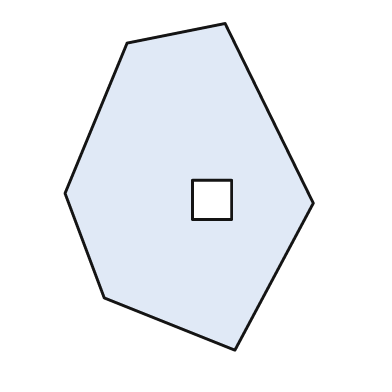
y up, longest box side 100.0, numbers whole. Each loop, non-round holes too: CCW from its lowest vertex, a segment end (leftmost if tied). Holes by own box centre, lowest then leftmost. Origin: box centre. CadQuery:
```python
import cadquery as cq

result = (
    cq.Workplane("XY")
    .moveTo(14.0, -50.0)
    .lineTo(38.0, -5.0)
    .lineTo(11.0, 50.0)
    .lineTo(-19.0, 44.0)
    .lineTo(-38.0, -2.0)
    .lineTo(-26.0, -34.0)
    .close()
    .moveTo(1.0, -10.0)
    .lineTo(13.0, -10.0)
    .lineTo(13.0, 2.0)
    .lineTo(1.0, 2.0)
    .close()
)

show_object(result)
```